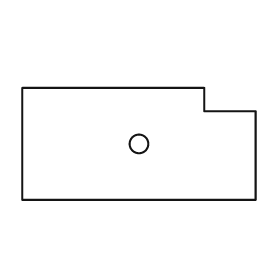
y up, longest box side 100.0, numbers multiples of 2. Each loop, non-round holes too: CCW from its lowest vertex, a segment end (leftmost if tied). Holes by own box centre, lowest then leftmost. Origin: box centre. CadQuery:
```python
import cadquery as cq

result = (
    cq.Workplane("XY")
    .moveTo(-50.0, -24.0)
    .lineTo(50.0, -24.0)
    .lineTo(50.0, 14.0)
    .lineTo(28.0, 14.0)
    .lineTo(28.0, 24.0)
    .lineTo(-50.0, 24.0)
    .close()
    .moveTo(0.0, 0.0)
    .circle(4.0)
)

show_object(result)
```